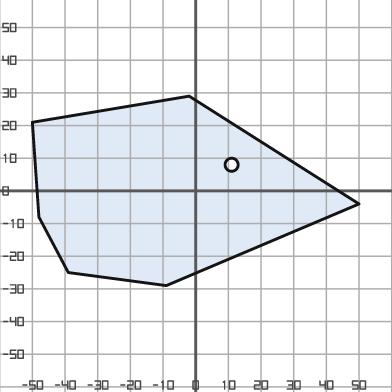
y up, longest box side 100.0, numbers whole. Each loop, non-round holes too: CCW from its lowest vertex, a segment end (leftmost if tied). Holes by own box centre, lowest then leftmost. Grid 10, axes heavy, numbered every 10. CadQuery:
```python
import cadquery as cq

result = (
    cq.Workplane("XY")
    .moveTo(-9.0, -29.0)
    .lineTo(50.0, -4.0)
    .lineTo(-2.0, 29.0)
    .lineTo(-50.0, 21.0)
    .lineTo(-48.0, -8.0)
    .lineTo(-39.0, -25.0)
    .close()
    .moveTo(11.0, 8.0)
    .circle(2.0)
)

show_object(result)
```